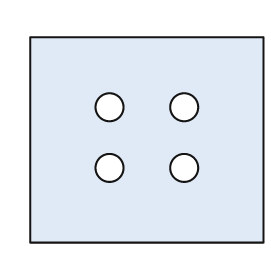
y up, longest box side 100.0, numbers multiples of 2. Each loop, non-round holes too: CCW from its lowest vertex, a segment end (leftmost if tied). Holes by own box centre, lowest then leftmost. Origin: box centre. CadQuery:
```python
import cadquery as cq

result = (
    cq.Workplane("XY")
    .moveTo(-50.0, -44.0)
    .lineTo(50.0, -44.0)
    .lineTo(50.0, 44.0)
    .lineTo(-50.0, 44.0)
    .close()
    .moveTo(-16.0, -12.0)
    .circle(6.0)
    .moveTo(16.0, -12.0)
    .circle(6.0)
    .moveTo(-16.0, 14.0)
    .circle(6.0)
    .moveTo(16.0, 14.0)
    .circle(6.0)
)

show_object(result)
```